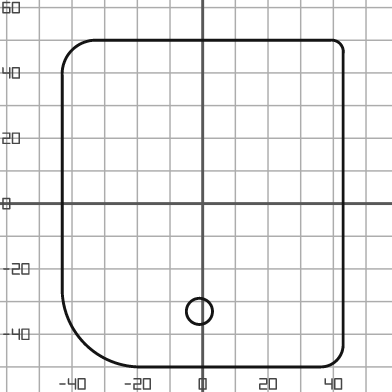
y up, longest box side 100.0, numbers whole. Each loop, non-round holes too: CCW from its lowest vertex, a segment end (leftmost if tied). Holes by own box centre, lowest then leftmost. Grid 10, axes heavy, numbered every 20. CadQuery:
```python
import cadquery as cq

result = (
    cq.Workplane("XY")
    .moveTo(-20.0, -50.0)
    .lineTo(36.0, -50.0)
    .threePointArc((41.0, -48.0), (43.0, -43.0))
    .lineTo(43.0, 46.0)
    .threePointArc((42.0, 49.0), (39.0, 50.0))
    .lineTo(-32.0, 50.0)
    .threePointArc((-40.0, 47.0), (-43.0, 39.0))
    .lineTo(-43.0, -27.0)
    .threePointArc((-36.0, -43.0), (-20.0, -50.0))
    .close()
    .moveTo(-1.0, -33.0)
    .circle(4.0)
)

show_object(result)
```